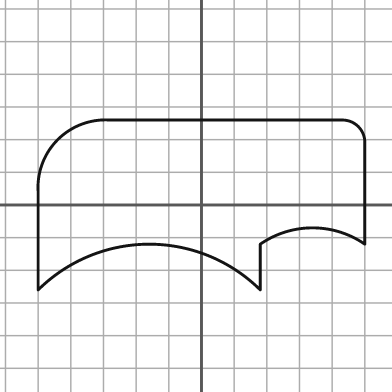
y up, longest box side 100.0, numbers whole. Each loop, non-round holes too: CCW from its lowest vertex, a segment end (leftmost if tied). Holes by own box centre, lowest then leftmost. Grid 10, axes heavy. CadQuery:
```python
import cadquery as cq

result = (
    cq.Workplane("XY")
    .moveTo(-50.0, -26.0)
    .threePointArc((-16.0, -12.0), (18.0, -26.0))
    .lineTo(18.0, -12.0)
    .threePointArc((34.0, -7.0), (50.0, -12.0))
    .lineTo(50.0, 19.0)
    .threePointArc((48.0, 24.0), (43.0, 26.0))
    .lineTo(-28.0, 26.0)
    .threePointArc((-44.0, 20.0), (-50.0, 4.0))
    .close()
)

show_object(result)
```